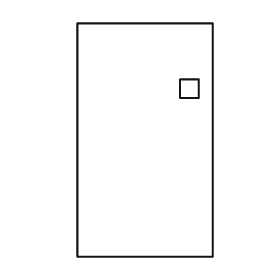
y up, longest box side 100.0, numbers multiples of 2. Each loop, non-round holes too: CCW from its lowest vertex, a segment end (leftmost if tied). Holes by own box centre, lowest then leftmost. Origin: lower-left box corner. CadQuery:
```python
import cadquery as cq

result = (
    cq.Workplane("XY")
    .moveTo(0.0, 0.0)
    .lineTo(58.0, 0.0)
    .lineTo(58.0, 100.0)
    .lineTo(0.0, 100.0)
    .close()
    .moveTo(44.0, 68.0)
    .lineTo(52.0, 68.0)
    .lineTo(52.0, 76.0)
    .lineTo(44.0, 76.0)
    .close()
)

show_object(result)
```